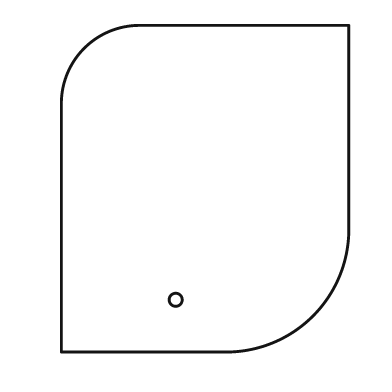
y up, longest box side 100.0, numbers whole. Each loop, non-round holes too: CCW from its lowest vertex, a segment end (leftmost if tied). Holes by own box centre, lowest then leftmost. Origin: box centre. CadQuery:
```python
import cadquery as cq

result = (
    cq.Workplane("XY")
    .moveTo(-44.0, -50.0)
    .lineTo(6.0, -50.0)
    .threePointArc((33.0, -39.0), (44.0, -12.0))
    .lineTo(44.0, 50.0)
    .lineTo(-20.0, 50.0)
    .threePointArc((-37.0, 43.0), (-44.0, 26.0))
    .close()
    .moveTo(-9.0, -34.0)
    .circle(2.0)
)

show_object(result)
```